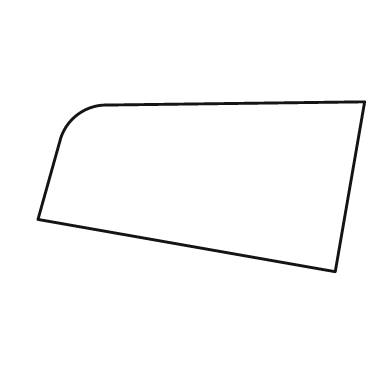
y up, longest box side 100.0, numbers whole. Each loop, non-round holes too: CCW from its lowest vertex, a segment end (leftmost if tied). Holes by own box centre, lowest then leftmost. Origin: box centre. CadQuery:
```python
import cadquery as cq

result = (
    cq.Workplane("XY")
    .moveTo(41.0, -26.0)
    .lineTo(50.0, 26.0)
    .lineTo(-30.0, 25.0)
    .threePointArc((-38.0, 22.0), (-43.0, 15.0))
    .lineTo(-50.0, -10.0)
    .close()
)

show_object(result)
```